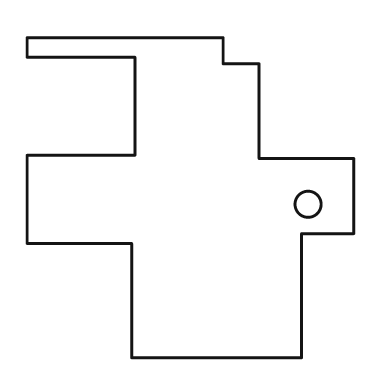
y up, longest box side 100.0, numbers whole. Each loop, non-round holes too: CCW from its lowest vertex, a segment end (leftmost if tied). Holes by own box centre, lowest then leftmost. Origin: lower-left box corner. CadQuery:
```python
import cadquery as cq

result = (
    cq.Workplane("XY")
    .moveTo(32.0, 0.0)
    .lineTo(84.0, 0.0)
    .lineTo(84.0, 38.0)
    .lineTo(100.0, 38.0)
    .lineTo(100.0, 61.0)
    .lineTo(71.0, 61.0)
    .lineTo(71.0, 90.0)
    .lineTo(60.0, 90.0)
    .lineTo(60.0, 98.0)
    .lineTo(0.0, 98.0)
    .lineTo(0.0, 92.0)
    .lineTo(33.0, 92.0)
    .lineTo(33.0, 62.0)
    .lineTo(0.0, 62.0)
    .lineTo(0.0, 35.0)
    .lineTo(32.0, 35.0)
    .close()
    .moveTo(86.0, 47.0)
    .circle(4.0)
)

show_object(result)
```